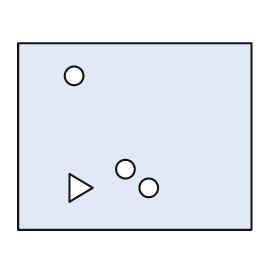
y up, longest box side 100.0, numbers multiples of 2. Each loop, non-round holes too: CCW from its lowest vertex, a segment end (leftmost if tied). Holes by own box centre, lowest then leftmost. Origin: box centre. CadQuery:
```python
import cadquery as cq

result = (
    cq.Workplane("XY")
    .moveTo(-50.0, -40.0)
    .lineTo(50.0, -40.0)
    .lineTo(50.0, 40.0)
    .lineTo(-50.0, 40.0)
    .close()
    .moveTo(-28.0, -28.0)
    .lineTo(-18.0, -22.0)
    .lineTo(-28.0, -16.0)
    .close()
    .moveTo(6.0, -22.0)
    .circle(4.0)
    .moveTo(-4.0, -14.0)
    .circle(4.0)
    .moveTo(-26.0, 26.0)
    .circle(4.0)
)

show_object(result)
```